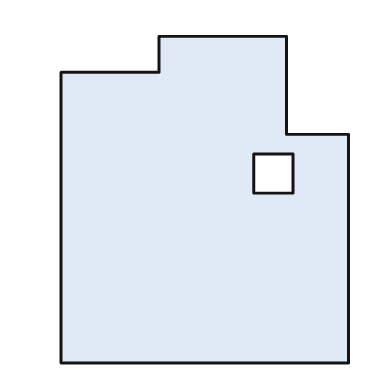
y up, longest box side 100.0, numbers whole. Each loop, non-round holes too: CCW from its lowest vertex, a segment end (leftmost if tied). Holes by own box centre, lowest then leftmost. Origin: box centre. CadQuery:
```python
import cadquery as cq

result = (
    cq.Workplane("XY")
    .moveTo(-44.0, -50.0)
    .lineTo(44.0, -50.0)
    .lineTo(44.0, 20.0)
    .lineTo(25.0, 20.0)
    .lineTo(25.0, 50.0)
    .lineTo(-14.0, 50.0)
    .lineTo(-14.0, 39.0)
    .lineTo(-44.0, 39.0)
    .close()
    .moveTo(15.0, 2.0)
    .lineTo(27.0, 2.0)
    .lineTo(27.0, 14.0)
    .lineTo(15.0, 14.0)
    .close()
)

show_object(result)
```